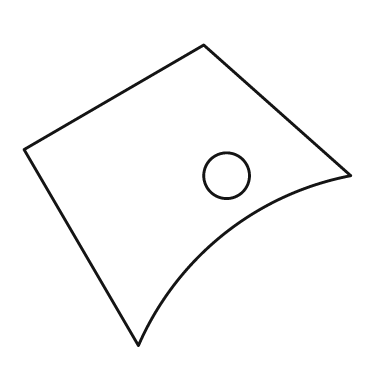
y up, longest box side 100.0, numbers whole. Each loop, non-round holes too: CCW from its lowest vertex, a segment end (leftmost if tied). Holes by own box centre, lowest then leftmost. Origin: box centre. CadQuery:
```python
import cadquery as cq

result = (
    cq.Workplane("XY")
    .moveTo(-15.0, -46.0)
    .threePointArc((11.0, -12.0), (50.0, 6.0))
    .lineTo(5.0, 46.0)
    .lineTo(-50.0, 14.0)
    .close()
    .moveTo(12.0, 6.0)
    .circle(7.0)
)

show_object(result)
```